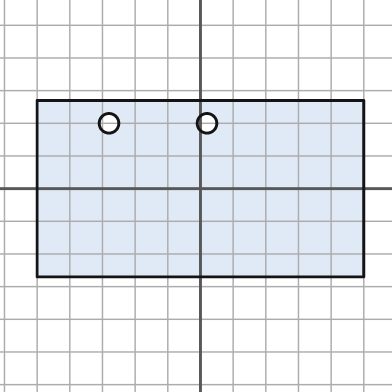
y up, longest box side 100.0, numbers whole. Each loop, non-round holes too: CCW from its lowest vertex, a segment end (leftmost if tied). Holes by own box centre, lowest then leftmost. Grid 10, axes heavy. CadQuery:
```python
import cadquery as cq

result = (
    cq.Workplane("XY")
    .moveTo(-50.0, -27.0)
    .lineTo(50.0, -27.0)
    .lineTo(50.0, 27.0)
    .lineTo(-50.0, 27.0)
    .close()
    .moveTo(-28.0, 20.0)
    .circle(3.0)
    .moveTo(2.0, 20.0)
    .circle(3.0)
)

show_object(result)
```